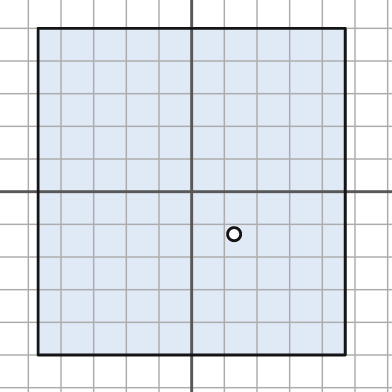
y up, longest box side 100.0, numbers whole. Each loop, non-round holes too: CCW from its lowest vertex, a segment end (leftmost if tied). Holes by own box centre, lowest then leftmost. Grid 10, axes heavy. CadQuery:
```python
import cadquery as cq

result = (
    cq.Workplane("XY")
    .moveTo(-47.0, -50.0)
    .lineTo(47.0, -50.0)
    .lineTo(47.0, 50.0)
    .lineTo(-47.0, 50.0)
    .close()
    .moveTo(13.0, -13.0)
    .circle(2.0)
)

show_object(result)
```